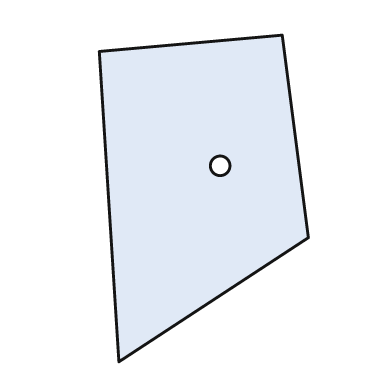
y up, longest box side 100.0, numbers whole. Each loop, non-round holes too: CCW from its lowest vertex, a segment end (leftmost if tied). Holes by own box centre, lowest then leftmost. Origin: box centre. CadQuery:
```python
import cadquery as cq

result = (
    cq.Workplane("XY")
    .moveTo(-26.0, -50.0)
    .lineTo(32.0, -12.0)
    .lineTo(24.0, 50.0)
    .lineTo(-32.0, 45.0)
    .close()
    .moveTo(5.0, 10.0)
    .circle(3.0)
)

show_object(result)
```